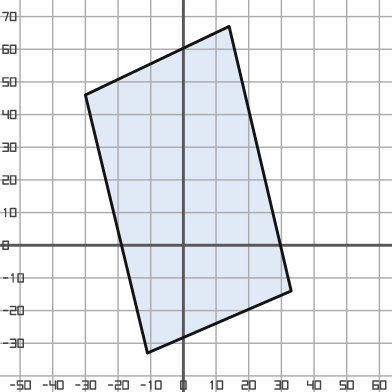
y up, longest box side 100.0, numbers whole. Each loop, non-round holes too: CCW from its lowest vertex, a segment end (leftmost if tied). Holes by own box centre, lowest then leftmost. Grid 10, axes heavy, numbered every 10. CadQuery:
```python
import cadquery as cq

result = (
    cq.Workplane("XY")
    .moveTo(-11.0, -33.0)
    .lineTo(33.0, -14.0)
    .lineTo(14.0, 67.0)
    .lineTo(-30.0, 46.0)
    .close()
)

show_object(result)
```